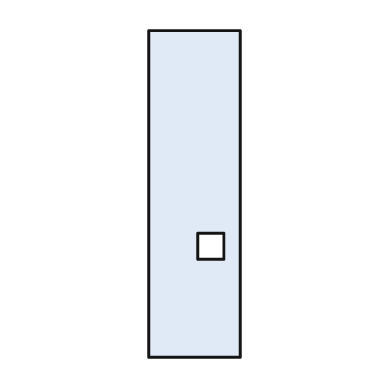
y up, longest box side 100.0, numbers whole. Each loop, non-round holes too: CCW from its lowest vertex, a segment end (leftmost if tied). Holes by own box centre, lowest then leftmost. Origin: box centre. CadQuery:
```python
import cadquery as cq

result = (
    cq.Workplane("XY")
    .moveTo(-14.0, -50.0)
    .lineTo(14.0, -50.0)
    .lineTo(14.0, 50.0)
    .lineTo(-14.0, 50.0)
    .close()
    .moveTo(1.0, -20.0)
    .lineTo(9.0, -20.0)
    .lineTo(9.0, -12.0)
    .lineTo(1.0, -12.0)
    .close()
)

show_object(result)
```